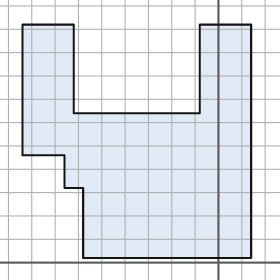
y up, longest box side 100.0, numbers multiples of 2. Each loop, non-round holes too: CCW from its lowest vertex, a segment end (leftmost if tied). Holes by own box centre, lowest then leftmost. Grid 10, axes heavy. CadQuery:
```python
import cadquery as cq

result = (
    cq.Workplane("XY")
    .moveTo(-58.0, 2.0)
    .lineTo(14.0, 2.0)
    .lineTo(14.0, 102.0)
    .lineTo(-8.0, 102.0)
    .lineTo(-8.0, 64.0)
    .lineTo(-62.0, 64.0)
    .lineTo(-62.0, 102.0)
    .lineTo(-84.0, 102.0)
    .lineTo(-84.0, 46.0)
    .lineTo(-66.0, 46.0)
    .lineTo(-66.0, 32.0)
    .lineTo(-58.0, 32.0)
    .close()
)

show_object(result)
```